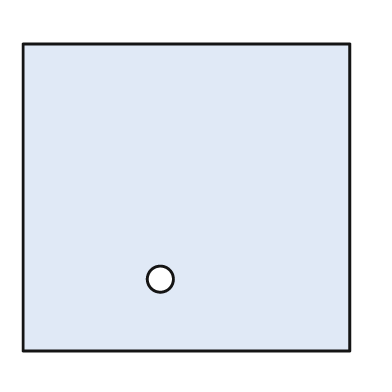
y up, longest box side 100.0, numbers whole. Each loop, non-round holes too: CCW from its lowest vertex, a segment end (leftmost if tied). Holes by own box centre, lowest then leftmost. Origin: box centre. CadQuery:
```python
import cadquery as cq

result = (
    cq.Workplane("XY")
    .moveTo(-50.0, -47.0)
    .lineTo(50.0, -47.0)
    .lineTo(50.0, 47.0)
    .lineTo(-50.0, 47.0)
    .close()
    .moveTo(-8.0, -25.0)
    .circle(4.0)
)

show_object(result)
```